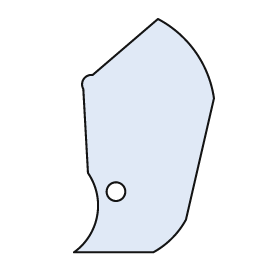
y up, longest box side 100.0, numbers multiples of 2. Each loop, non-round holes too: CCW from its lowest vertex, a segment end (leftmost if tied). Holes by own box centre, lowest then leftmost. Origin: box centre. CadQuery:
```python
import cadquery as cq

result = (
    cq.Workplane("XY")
    .moveTo(-30.0, -50.0)
    .lineTo(4.0, -50.0)
    .threePointArc((12.0, -44.0), (18.0, -36.0))
    .lineTo(30.0, 16.0)
    .threePointArc((22.0, 36.0), (6.0, 50.0))
    .lineTo(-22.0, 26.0)
    .threePointArc((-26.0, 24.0), (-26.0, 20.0))
    .lineTo(-24.0, -16.0)
    .threePointArc((-20.0, -34.0), (-30.0, -50.0))
    .close()
    .moveTo(-12.0, -24.0)
    .circle(4.0)
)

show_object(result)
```